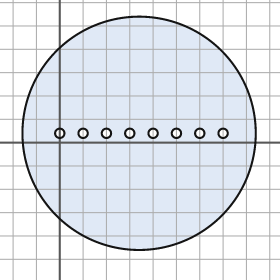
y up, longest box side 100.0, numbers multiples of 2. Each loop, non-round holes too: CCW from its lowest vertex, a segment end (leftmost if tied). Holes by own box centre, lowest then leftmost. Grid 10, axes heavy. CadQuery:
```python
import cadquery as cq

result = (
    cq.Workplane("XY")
    .moveTo(34.0, 4.0)
    .circle(50.0)
    .moveTo(0.0, 4.0)
    .circle(2.0)
    .moveTo(10.0, 4.0)
    .circle(2.0)
    .moveTo(20.0, 4.0)
    .circle(2.0)
    .moveTo(30.0, 4.0)
    .circle(2.0)
    .moveTo(40.0, 4.0)
    .circle(2.0)
    .moveTo(50.0, 4.0)
    .circle(2.0)
    .moveTo(60.0, 4.0)
    .circle(2.0)
    .moveTo(70.0, 4.0)
    .circle(2.0)
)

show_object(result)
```